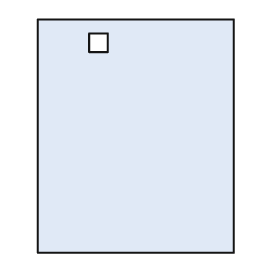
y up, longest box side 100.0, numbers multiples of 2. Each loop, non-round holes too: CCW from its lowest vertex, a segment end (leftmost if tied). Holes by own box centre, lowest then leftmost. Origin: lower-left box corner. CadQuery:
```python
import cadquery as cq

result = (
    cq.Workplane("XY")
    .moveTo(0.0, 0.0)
    .lineTo(84.0, 0.0)
    .lineTo(84.0, 100.0)
    .lineTo(0.0, 100.0)
    .close()
    .moveTo(22.0, 86.0)
    .lineTo(30.0, 86.0)
    .lineTo(30.0, 94.0)
    .lineTo(22.0, 94.0)
    .close()
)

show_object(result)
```